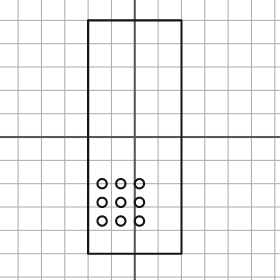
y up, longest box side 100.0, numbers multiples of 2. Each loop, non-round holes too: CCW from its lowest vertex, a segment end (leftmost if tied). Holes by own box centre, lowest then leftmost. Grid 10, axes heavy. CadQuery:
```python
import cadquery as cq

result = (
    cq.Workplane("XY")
    .moveTo(-20.0, -50.0)
    .lineTo(20.0, -50.0)
    .lineTo(20.0, 50.0)
    .lineTo(-20.0, 50.0)
    .close()
    .moveTo(-14.0, -36.0)
    .circle(2.0)
    .moveTo(-6.0, -36.0)
    .circle(2.0)
    .moveTo(2.0, -36.0)
    .circle(2.0)
    .moveTo(-14.0, -28.0)
    .circle(2.0)
    .moveTo(-6.0, -28.0)
    .circle(2.0)
    .moveTo(2.0, -28.0)
    .circle(2.0)
    .moveTo(-14.0, -20.0)
    .circle(2.0)
    .moveTo(-6.0, -20.0)
    .circle(2.0)
    .moveTo(2.0, -20.0)
    .circle(2.0)
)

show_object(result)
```